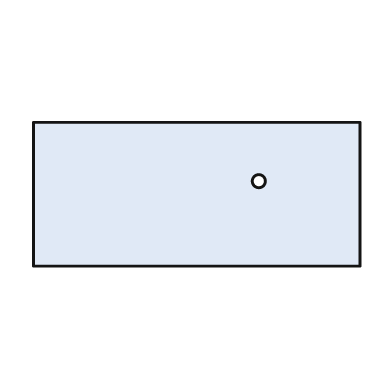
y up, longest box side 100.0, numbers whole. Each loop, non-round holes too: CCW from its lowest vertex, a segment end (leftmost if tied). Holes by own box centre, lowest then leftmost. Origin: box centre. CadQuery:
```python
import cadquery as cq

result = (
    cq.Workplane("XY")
    .moveTo(-50.0, -22.0)
    .lineTo(50.0, -22.0)
    .lineTo(50.0, 22.0)
    .lineTo(-50.0, 22.0)
    .close()
    .moveTo(19.0, 4.0)
    .circle(2.0)
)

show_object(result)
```